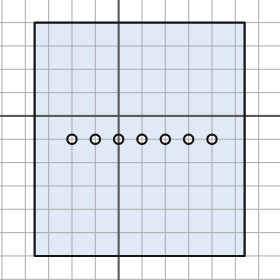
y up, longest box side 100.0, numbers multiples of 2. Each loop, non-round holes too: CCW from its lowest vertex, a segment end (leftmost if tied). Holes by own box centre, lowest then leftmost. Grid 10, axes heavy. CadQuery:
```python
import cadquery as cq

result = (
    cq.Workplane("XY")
    .moveTo(-36.0, -60.0)
    .lineTo(54.0, -60.0)
    .lineTo(54.0, 40.0)
    .lineTo(-36.0, 40.0)
    .close()
    .moveTo(-20.0, -10.0)
    .circle(2.0)
    .moveTo(-10.0, -10.0)
    .circle(2.0)
    .moveTo(0.0, -10.0)
    .circle(2.0)
    .moveTo(10.0, -10.0)
    .circle(2.0)
    .moveTo(20.0, -10.0)
    .circle(2.0)
    .moveTo(30.0, -10.0)
    .circle(2.0)
    .moveTo(40.0, -10.0)
    .circle(2.0)
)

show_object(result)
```